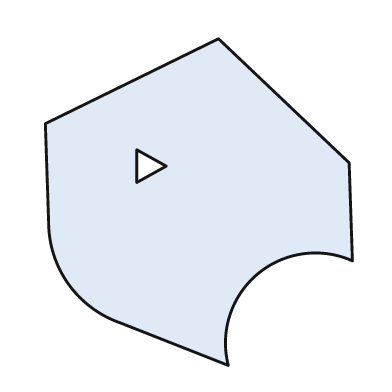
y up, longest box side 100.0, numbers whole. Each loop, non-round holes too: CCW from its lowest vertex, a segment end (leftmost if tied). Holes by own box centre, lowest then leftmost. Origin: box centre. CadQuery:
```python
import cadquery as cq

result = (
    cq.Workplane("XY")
    .moveTo(9.0, -50.0)
    .threePointArc((18.0, -22.0), (47.0, -18.0))
    .lineTo(46.0, 12.0)
    .lineTo(6.0, 50.0)
    .lineTo(-47.0, 24.0)
    .lineTo(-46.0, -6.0)
    .threePointArc((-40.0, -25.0), (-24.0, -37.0))
    .close()
    .moveTo(-19.0, 6.0)
    .lineTo(-10.0, 11.0)
    .lineTo(-19.0, 16.0)
    .close()
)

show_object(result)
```